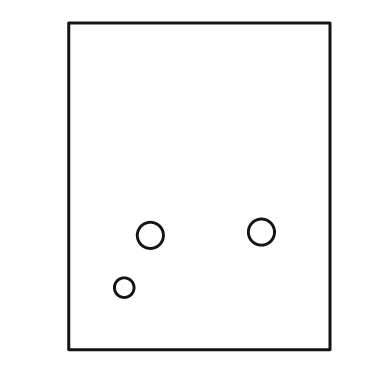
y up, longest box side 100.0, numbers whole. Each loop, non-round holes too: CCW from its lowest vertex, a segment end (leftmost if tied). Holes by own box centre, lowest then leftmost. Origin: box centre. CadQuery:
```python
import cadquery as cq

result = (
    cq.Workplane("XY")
    .moveTo(-40.0, -50.0)
    .lineTo(40.0, -50.0)
    .lineTo(40.0, 50.0)
    .lineTo(-40.0, 50.0)
    .close()
    .moveTo(-23.0, -31.0)
    .circle(3.0)
    .moveTo(-15.0, -15.0)
    .circle(4.0)
    .moveTo(19.0, -14.0)
    .circle(4.0)
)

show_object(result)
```